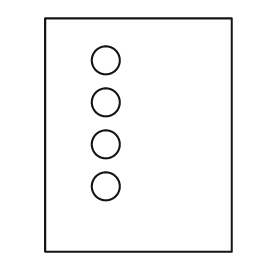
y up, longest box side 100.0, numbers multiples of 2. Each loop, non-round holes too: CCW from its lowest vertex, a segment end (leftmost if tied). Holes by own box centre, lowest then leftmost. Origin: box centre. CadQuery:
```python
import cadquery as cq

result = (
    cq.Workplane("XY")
    .moveTo(-40.0, -50.0)
    .lineTo(40.0, -50.0)
    .lineTo(40.0, 50.0)
    .lineTo(-40.0, 50.0)
    .close()
    .moveTo(-14.0, -22.0)
    .circle(6.0)
    .moveTo(-14.0, -4.0)
    .circle(6.0)
    .moveTo(-14.0, 14.0)
    .circle(6.0)
    .moveTo(-14.0, 32.0)
    .circle(6.0)
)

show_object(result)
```